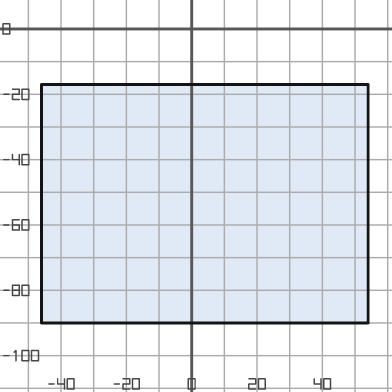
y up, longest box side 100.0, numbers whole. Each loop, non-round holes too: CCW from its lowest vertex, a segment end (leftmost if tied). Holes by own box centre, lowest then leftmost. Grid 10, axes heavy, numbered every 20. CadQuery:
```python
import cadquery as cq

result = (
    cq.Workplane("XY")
    .moveTo(-46.0, -90.0)
    .lineTo(54.0, -90.0)
    .lineTo(54.0, -17.0)
    .lineTo(-46.0, -17.0)
    .close()
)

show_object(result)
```